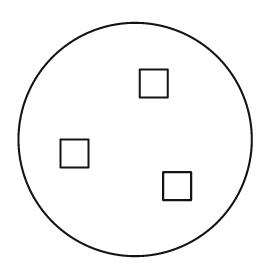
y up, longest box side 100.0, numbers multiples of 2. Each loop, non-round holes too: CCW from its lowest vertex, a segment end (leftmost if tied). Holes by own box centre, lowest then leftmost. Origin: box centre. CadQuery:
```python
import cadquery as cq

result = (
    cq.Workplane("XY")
    .moveTo(0.0, 0.0)
    .circle(50.0)
    .moveTo(12.0, -26.0)
    .lineTo(24.0, -26.0)
    .lineTo(24.0, -14.0)
    .lineTo(12.0, -14.0)
    .close()
    .moveTo(-32.0, -12.0)
    .lineTo(-20.0, -12.0)
    .lineTo(-20.0, 0.0)
    .lineTo(-32.0, 0.0)
    .close()
    .moveTo(2.0, 18.0)
    .lineTo(14.0, 18.0)
    .lineTo(14.0, 30.0)
    .lineTo(2.0, 30.0)
    .close()
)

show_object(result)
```